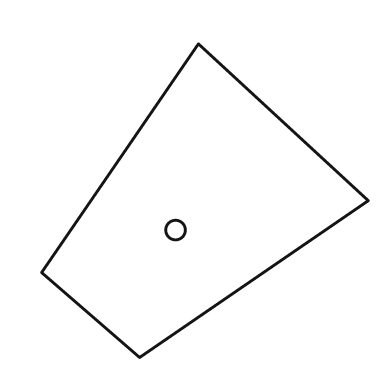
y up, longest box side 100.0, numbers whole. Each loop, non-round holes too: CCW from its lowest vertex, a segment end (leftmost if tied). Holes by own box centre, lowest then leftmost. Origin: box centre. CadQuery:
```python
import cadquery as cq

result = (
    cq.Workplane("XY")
    .moveTo(-20.0, -48.0)
    .lineTo(50.0, 0.0)
    .lineTo(-2.0, 48.0)
    .lineTo(-50.0, -22.0)
    .close()
    .moveTo(-9.0, -9.0)
    .circle(3.0)
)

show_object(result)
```